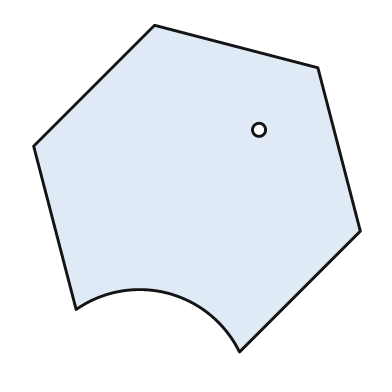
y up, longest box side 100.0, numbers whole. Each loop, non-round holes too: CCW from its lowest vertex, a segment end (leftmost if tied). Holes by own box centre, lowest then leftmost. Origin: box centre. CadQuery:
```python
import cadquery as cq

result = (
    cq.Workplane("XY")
    .moveTo(13.0, -50.0)
    .lineTo(50.0, -13.0)
    .lineTo(37.0, 37.0)
    .lineTo(-13.0, 50.0)
    .lineTo(-50.0, 13.0)
    .lineTo(-37.0, -37.0)
    .threePointArc((-9.0, -32.0), (13.0, -50.0))
    .close()
    .moveTo(19.0, 18.0)
    .circle(2.0)
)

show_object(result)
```